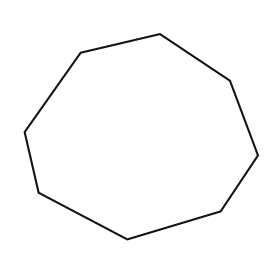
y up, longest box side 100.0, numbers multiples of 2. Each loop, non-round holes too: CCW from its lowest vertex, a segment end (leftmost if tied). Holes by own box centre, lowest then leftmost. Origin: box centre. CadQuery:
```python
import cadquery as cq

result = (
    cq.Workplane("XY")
    .moveTo(-6.0, -44.0)
    .lineTo(34.0, -32.0)
    .lineTo(50.0, -8.0)
    .lineTo(38.0, 24.0)
    .lineTo(8.0, 44.0)
    .lineTo(-26.0, 36.0)
    .lineTo(-50.0, 2.0)
    .lineTo(-44.0, -24.0)
    .close()
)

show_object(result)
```